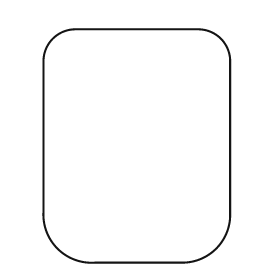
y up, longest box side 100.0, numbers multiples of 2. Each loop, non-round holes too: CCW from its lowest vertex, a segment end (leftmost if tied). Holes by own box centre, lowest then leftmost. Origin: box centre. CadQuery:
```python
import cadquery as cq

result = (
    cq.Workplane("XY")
    .moveTo(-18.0, -50.0)
    .lineTo(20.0, -50.0)
    .threePointArc((34.0, -44.0), (40.0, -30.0))
    .lineTo(40.0, 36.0)
    .threePointArc((36.0, 46.0), (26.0, 50.0))
    .lineTo(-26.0, 50.0)
    .threePointArc((-36.0, 46.0), (-40.0, 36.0))
    .lineTo(-40.0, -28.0)
    .threePointArc((-34.0, -44.0), (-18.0, -50.0))
    .close()
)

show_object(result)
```